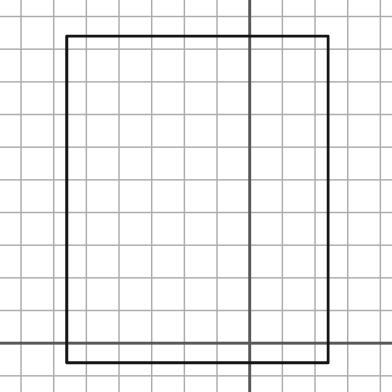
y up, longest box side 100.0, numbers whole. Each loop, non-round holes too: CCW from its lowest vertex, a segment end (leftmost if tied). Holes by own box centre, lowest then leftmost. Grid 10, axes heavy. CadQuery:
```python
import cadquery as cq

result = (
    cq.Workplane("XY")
    .moveTo(-56.0, -6.0)
    .lineTo(24.0, -6.0)
    .lineTo(24.0, 94.0)
    .lineTo(-56.0, 94.0)
    .close()
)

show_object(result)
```